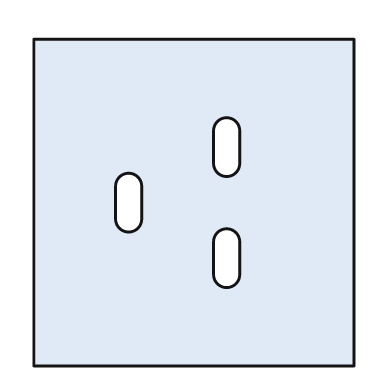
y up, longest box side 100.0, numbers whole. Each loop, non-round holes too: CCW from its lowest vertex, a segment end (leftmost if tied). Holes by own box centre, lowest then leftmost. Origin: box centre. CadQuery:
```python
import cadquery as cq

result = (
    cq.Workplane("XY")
    .moveTo(-49.0, -50.0)
    .lineTo(49.0, -50.0)
    .lineTo(49.0, 50.0)
    .lineTo(-49.0, 50.0)
    .close()
    .moveTo(6.0, -22.0)
    .threePointArc((10.0, -26.0), (14.0, -22.0))
    .lineTo(14.0, -12.0)
    .threePointArc((10.0, -8.0), (6.0, -12.0))
    .close()
    .moveTo(-24.0, -5.0)
    .threePointArc((-20.0, -9.0), (-16.0, -5.0))
    .lineTo(-16.0, 5.0)
    .threePointArc((-20.0, 9.0), (-24.0, 5.0))
    .close()
    .moveTo(6.0, 12.0)
    .threePointArc((10.0, 8.0), (14.0, 12.0))
    .lineTo(14.0, 22.0)
    .threePointArc((10.0, 26.0), (6.0, 22.0))
    .close()
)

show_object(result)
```